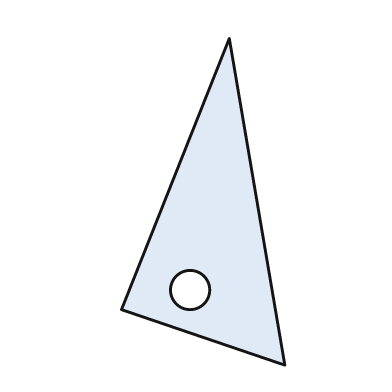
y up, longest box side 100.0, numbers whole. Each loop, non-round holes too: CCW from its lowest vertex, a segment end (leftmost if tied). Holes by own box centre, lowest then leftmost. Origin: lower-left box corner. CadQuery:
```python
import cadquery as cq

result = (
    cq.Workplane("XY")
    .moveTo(50.0, 0.0)
    .lineTo(33.0, 100.0)
    .lineTo(0.0, 17.0)
    .close()
    .moveTo(21.0, 23.0)
    .circle(6.0)
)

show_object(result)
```